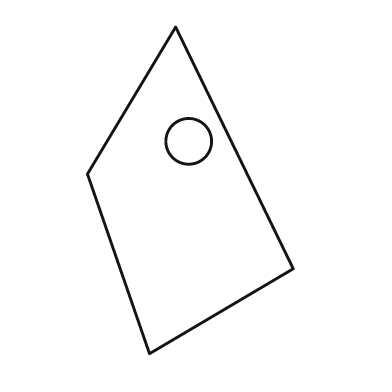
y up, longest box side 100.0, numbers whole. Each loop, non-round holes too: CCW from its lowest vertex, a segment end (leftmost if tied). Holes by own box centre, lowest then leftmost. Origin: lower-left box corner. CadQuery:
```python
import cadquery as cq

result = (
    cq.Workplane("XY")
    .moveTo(19.0, 0.0)
    .lineTo(63.0, 26.0)
    .lineTo(27.0, 100.0)
    .lineTo(0.0, 55.0)
    .close()
    .moveTo(31.0, 65.0)
    .circle(7.0)
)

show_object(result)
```